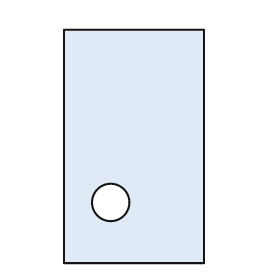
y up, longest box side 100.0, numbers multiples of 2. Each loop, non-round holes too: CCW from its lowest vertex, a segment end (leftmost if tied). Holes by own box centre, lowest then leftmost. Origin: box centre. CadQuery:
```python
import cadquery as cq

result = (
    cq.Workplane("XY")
    .moveTo(-30.0, -50.0)
    .lineTo(30.0, -50.0)
    .lineTo(30.0, 50.0)
    .lineTo(-30.0, 50.0)
    .close()
    .moveTo(-10.0, -24.0)
    .circle(8.0)
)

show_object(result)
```